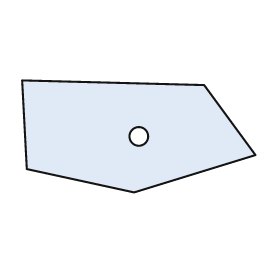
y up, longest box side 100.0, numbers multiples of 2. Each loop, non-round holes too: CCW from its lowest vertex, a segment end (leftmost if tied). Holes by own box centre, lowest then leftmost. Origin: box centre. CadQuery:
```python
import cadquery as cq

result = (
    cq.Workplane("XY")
    .moveTo(-2.0, -24.0)
    .lineTo(50.0, -8.0)
    .lineTo(28.0, 22.0)
    .lineTo(-50.0, 24.0)
    .lineTo(-48.0, -14.0)
    .close()
    .moveTo(0.0, 0.0)
    .circle(4.0)
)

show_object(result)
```